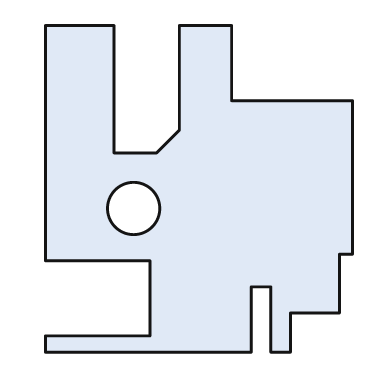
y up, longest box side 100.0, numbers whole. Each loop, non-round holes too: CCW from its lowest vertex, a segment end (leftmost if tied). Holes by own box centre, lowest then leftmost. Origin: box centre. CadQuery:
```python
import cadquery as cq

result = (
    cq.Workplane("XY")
    .moveTo(-47.0, -50.0)
    .lineTo(16.0, -50.0)
    .lineTo(16.0, -30.0)
    .lineTo(22.0, -30.0)
    .lineTo(22.0, -50.0)
    .lineTo(28.0, -50.0)
    .lineTo(28.0, -38.0)
    .lineTo(43.0, -38.0)
    .lineTo(43.0, -20.0)
    .lineTo(47.0, -20.0)
    .lineTo(47.0, 27.0)
    .lineTo(10.0, 27.0)
    .lineTo(10.0, 50.0)
    .lineTo(-6.0, 50.0)
    .lineTo(-6.0, 18.0)
    .lineTo(-13.0, 11.0)
    .lineTo(-26.0, 11.0)
    .lineTo(-26.0, 50.0)
    .lineTo(-47.0, 50.0)
    .lineTo(-47.0, -22.0)
    .lineTo(-15.0, -22.0)
    .lineTo(-15.0, -45.0)
    .lineTo(-47.0, -45.0)
    .close()
    .moveTo(-20.0, -6.0)
    .circle(8.0)
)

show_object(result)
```